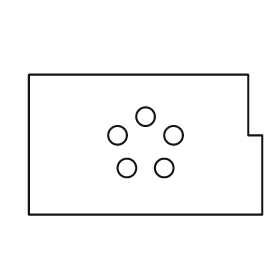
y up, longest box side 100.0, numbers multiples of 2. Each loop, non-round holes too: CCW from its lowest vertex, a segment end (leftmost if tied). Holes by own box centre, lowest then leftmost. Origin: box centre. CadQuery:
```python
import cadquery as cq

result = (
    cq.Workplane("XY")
    .moveTo(-50.0, -30.0)
    .lineTo(50.0, -30.0)
    .lineTo(50.0, 4.0)
    .lineTo(44.0, 4.0)
    .lineTo(44.0, 30.0)
    .lineTo(-50.0, 30.0)
    .close()
    .moveTo(-8.0, -10.0)
    .circle(4.0)
    .moveTo(8.0, -10.0)
    .circle(4.0)
    .moveTo(-12.0, 4.0)
    .circle(4.0)
    .moveTo(12.0, 4.0)
    .circle(4.0)
    .moveTo(0.0, 12.0)
    .circle(4.0)
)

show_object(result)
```